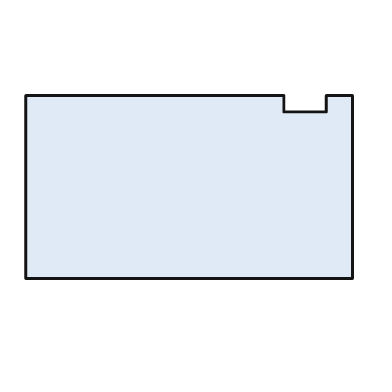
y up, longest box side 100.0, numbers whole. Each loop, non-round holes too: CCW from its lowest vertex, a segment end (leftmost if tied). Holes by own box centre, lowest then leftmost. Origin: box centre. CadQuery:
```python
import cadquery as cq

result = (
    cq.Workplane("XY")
    .moveTo(-50.0, -28.0)
    .lineTo(50.0, -28.0)
    .lineTo(50.0, 28.0)
    .lineTo(42.0, 28.0)
    .lineTo(42.0, 23.0)
    .lineTo(29.0, 23.0)
    .lineTo(29.0, 28.0)
    .lineTo(-50.0, 28.0)
    .close()
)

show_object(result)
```